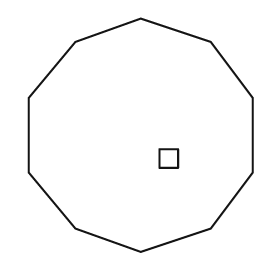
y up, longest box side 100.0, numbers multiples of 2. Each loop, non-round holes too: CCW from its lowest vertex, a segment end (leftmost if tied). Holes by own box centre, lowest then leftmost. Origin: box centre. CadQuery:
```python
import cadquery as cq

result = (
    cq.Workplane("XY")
    .moveTo(0.0, -50.0)
    .lineTo(30.0, -40.0)
    .lineTo(48.0, -16.0)
    .lineTo(48.0, 16.0)
    .lineTo(30.0, 40.0)
    .lineTo(0.0, 50.0)
    .lineTo(-28.0, 40.0)
    .lineTo(-48.0, 16.0)
    .lineTo(-48.0, -16.0)
    .lineTo(-28.0, -40.0)
    .close()
    .moveTo(8.0, -14.0)
    .lineTo(16.0, -14.0)
    .lineTo(16.0, -6.0)
    .lineTo(8.0, -6.0)
    .close()
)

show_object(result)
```